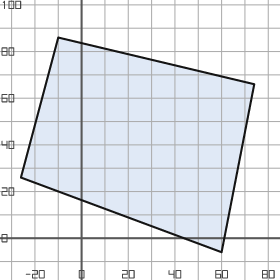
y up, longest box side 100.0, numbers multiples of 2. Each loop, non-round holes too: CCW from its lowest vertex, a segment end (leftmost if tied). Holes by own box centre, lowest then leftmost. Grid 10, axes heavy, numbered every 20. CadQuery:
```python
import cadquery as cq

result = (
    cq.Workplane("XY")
    .moveTo(60.0, -6.0)
    .lineTo(74.0, 66.0)
    .lineTo(-10.0, 86.0)
    .lineTo(-26.0, 26.0)
    .close()
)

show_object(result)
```